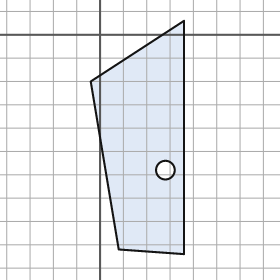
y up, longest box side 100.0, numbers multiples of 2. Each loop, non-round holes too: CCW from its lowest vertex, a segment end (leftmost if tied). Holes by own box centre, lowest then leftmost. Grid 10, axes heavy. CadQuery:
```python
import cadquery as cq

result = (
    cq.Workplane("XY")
    .moveTo(36.0, -94.0)
    .lineTo(36.0, 6.0)
    .lineTo(-4.0, -20.0)
    .lineTo(8.0, -92.0)
    .close()
    .moveTo(28.0, -58.0)
    .circle(4.0)
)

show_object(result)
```